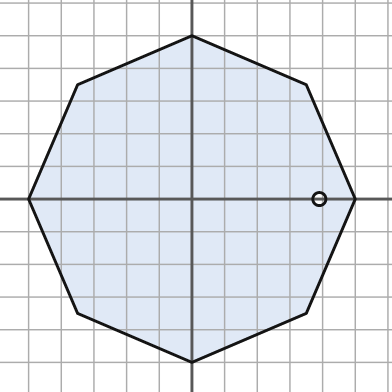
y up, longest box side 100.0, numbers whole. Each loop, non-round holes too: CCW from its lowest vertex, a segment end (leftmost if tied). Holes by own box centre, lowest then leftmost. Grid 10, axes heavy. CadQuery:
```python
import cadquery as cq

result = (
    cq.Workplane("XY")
    .moveTo(0.0, -50.0)
    .lineTo(35.0, -35.0)
    .lineTo(50.0, 0.0)
    .lineTo(35.0, 35.0)
    .lineTo(0.0, 50.0)
    .lineTo(-35.0, 35.0)
    .lineTo(-50.0, 0.0)
    .lineTo(-35.0, -35.0)
    .close()
    .moveTo(39.0, 0.0)
    .circle(2.0)
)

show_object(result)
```